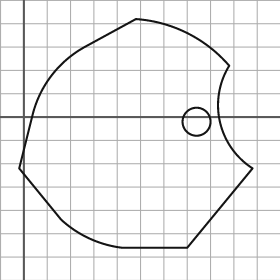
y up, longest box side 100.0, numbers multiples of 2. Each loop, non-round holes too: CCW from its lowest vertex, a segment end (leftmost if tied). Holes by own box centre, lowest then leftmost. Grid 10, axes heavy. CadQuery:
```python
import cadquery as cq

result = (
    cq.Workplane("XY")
    .moveTo(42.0, -56.0)
    .lineTo(70.0, -56.0)
    .lineTo(98.0, -22.0)
    .threePointArc((84.0, -2.0), (88.0, 22.0))
    .threePointArc((70.0, 36.0), (48.0, 42.0))
    .lineTo(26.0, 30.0)
    .threePointArc((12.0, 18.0), (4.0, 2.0))
    .lineTo(-2.0, -22.0)
    .lineTo(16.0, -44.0)
    .threePointArc((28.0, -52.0), (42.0, -56.0))
    .close()
    .moveTo(74.0, -2.0)
    .circle(6.0)
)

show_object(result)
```